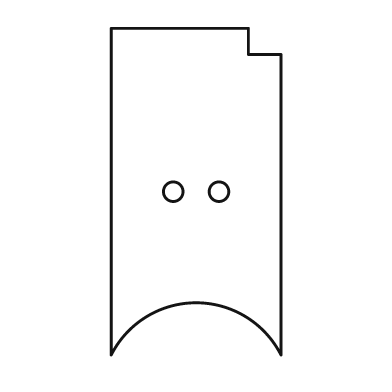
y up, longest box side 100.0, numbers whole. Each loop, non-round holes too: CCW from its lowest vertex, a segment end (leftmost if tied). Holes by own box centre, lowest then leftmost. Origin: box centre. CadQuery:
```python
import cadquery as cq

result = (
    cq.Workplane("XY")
    .moveTo(-26.0, -50.0)
    .threePointArc((0.0, -34.0), (26.0, -50.0))
    .lineTo(26.0, 42.0)
    .lineTo(16.0, 42.0)
    .lineTo(16.0, 50.0)
    .lineTo(-26.0, 50.0)
    .close()
    .moveTo(-7.0, 0.0)
    .circle(3.0)
    .moveTo(7.0, 0.0)
    .circle(3.0)
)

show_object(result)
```